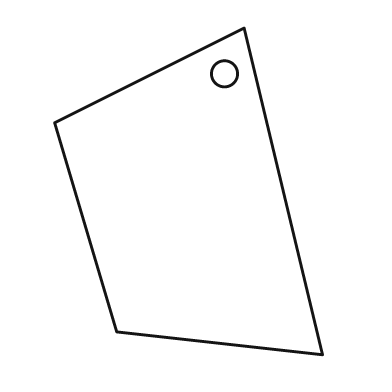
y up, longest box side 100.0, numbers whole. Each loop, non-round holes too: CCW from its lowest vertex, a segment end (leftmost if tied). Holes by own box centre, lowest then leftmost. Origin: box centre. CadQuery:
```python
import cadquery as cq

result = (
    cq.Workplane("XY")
    .moveTo(41.0, -50.0)
    .lineTo(17.0, 50.0)
    .lineTo(-41.0, 21.0)
    .lineTo(-22.0, -43.0)
    .close()
    .moveTo(11.0, 36.0)
    .circle(4.0)
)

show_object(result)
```